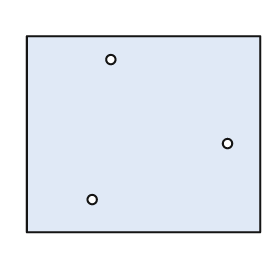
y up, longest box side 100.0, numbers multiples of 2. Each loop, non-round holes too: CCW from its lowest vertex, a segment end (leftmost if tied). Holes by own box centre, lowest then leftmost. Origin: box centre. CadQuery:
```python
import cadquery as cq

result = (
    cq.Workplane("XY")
    .moveTo(-50.0, -42.0)
    .lineTo(50.0, -42.0)
    .lineTo(50.0, 42.0)
    .lineTo(-50.0, 42.0)
    .close()
    .moveTo(-22.0, -28.0)
    .circle(2.0)
    .moveTo(36.0, -4.0)
    .circle(2.0)
    .moveTo(-14.0, 32.0)
    .circle(2.0)
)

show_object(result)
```